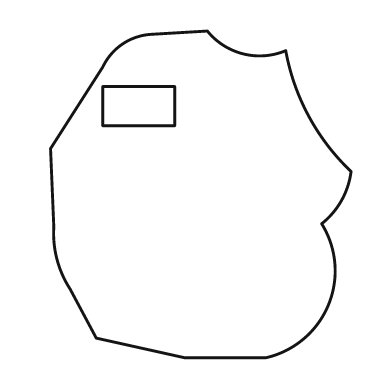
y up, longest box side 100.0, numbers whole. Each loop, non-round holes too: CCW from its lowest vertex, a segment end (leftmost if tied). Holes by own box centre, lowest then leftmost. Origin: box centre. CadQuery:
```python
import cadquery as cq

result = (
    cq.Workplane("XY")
    .moveTo(-5.0, -50.0)
    .lineTo(20.0, -50.0)
    .threePointArc((39.0, -34.0), (37.0, -9.0))
    .threePointArc((43.0, -2.0), (46.0, 7.0))
    .threePointArc((33.0, 24.0), (26.0, 44.0))
    .threePointArc((13.0, 43.0), (2.0, 50.0))
    .lineTo(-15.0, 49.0)
    .threePointArc((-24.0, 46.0), (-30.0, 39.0))
    .lineTo(-46.0, 14.0)
    .lineTo(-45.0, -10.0)
    .threePointArc((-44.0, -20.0), (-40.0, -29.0))
    .lineTo(-32.0, -44.0)
    .close()
    .moveTo(-30.0, 21.0)
    .lineTo(-8.0, 21.0)
    .lineTo(-8.0, 33.0)
    .lineTo(-30.0, 33.0)
    .close()
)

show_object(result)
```